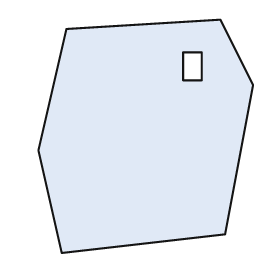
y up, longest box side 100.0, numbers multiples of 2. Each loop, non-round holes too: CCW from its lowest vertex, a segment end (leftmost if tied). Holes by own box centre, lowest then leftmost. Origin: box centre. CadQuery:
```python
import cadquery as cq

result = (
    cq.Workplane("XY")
    .moveTo(-36.0, -50.0)
    .lineTo(34.0, -42.0)
    .lineTo(46.0, 22.0)
    .lineTo(32.0, 50.0)
    .lineTo(-34.0, 46.0)
    .lineTo(-46.0, -6.0)
    .close()
    .moveTo(16.0, 24.0)
    .lineTo(24.0, 24.0)
    .lineTo(24.0, 36.0)
    .lineTo(16.0, 36.0)
    .close()
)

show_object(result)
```